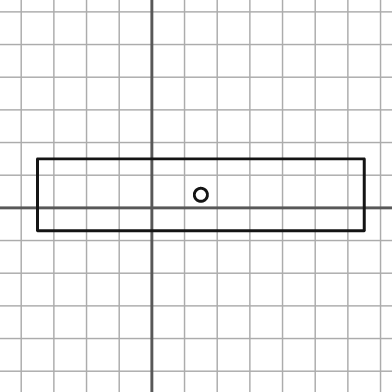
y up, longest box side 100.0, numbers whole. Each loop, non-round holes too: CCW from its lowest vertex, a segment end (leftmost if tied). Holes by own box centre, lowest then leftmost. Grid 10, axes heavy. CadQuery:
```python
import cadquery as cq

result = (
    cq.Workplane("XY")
    .moveTo(-35.0, -7.0)
    .lineTo(65.0, -7.0)
    .lineTo(65.0, 15.0)
    .lineTo(-35.0, 15.0)
    .close()
    .moveTo(15.0, 4.0)
    .circle(2.0)
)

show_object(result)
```